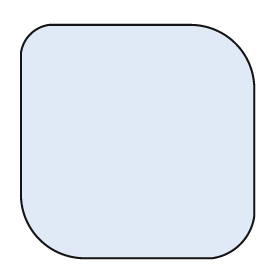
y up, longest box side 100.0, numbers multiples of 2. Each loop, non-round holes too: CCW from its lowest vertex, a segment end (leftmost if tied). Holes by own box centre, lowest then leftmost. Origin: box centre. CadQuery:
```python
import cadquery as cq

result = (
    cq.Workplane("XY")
    .moveTo(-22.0, -50.0)
    .lineTo(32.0, -50.0)
    .threePointArc((44.0, -44.0), (50.0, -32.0))
    .lineTo(50.0, 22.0)
    .threePointArc((42.0, 42.0), (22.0, 50.0))
    .lineTo(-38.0, 50.0)
    .threePointArc((-46.0, 46.0), (-50.0, 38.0))
    .lineTo(-50.0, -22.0)
    .threePointArc((-42.0, -42.0), (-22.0, -50.0))
    .close()
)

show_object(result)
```